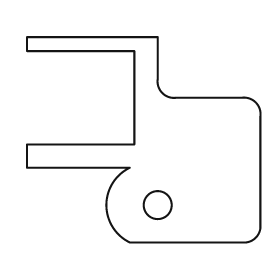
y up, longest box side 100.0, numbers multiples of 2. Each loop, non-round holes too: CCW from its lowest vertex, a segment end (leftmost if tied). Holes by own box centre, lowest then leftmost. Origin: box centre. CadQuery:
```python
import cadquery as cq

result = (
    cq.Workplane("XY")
    .moveTo(-6.0, -44.0)
    .lineTo(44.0, -44.0)
    .threePointArc((48.0, -42.0), (50.0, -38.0))
    .lineTo(50.0, 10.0)
    .threePointArc((48.0, 16.0), (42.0, 18.0))
    .lineTo(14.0, 18.0)
    .threePointArc((8.0, 20.0), (6.0, 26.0))
    .lineTo(6.0, 44.0)
    .lineTo(-50.0, 44.0)
    .lineTo(-50.0, 38.0)
    .lineTo(-4.0, 38.0)
    .lineTo(-4.0, -2.0)
    .lineTo(-50.0, -2.0)
    .lineTo(-50.0, -12.0)
    .lineTo(-6.0, -12.0)
    .threePointArc((-16.0, -28.0), (-6.0, -44.0))
    .close()
    .moveTo(6.0, -28.0)
    .circle(6.0)
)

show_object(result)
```